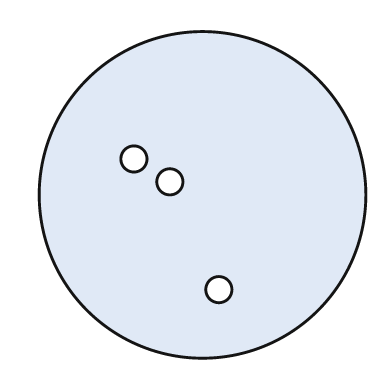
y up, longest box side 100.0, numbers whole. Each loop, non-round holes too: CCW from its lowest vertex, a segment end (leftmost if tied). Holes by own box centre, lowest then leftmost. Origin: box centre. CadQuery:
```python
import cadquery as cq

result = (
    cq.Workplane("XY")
    .moveTo(0.0, 0.0)
    .circle(50.0)
    .moveTo(5.0, -29.0)
    .circle(4.0)
    .moveTo(-10.0, 4.0)
    .circle(4.0)
    .moveTo(-21.0, 11.0)
    .circle(4.0)
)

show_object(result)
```